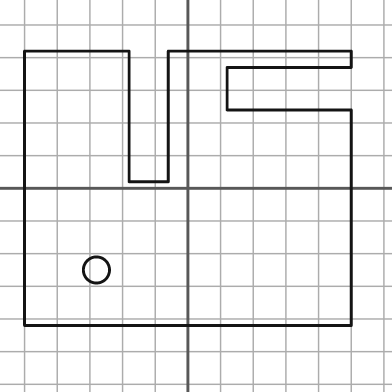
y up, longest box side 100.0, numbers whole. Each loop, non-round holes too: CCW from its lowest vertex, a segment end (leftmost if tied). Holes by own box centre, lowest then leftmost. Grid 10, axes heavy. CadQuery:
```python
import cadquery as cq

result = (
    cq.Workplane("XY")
    .moveTo(-50.0, -42.0)
    .lineTo(50.0, -42.0)
    .lineTo(50.0, 24.0)
    .lineTo(12.0, 24.0)
    .lineTo(12.0, 37.0)
    .lineTo(50.0, 37.0)
    .lineTo(50.0, 42.0)
    .lineTo(-6.0, 42.0)
    .lineTo(-6.0, 2.0)
    .lineTo(-18.0, 2.0)
    .lineTo(-18.0, 42.0)
    .lineTo(-50.0, 42.0)
    .close()
    .moveTo(-28.0, -25.0)
    .circle(4.0)
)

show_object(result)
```